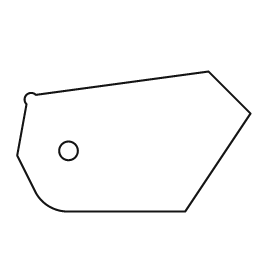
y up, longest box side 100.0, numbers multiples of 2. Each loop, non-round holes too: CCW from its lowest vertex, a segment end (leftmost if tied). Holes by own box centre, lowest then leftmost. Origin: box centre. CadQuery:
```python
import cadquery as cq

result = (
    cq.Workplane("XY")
    .moveTo(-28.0, -30.0)
    .lineTo(22.0, -30.0)
    .lineTo(50.0, 12.0)
    .lineTo(32.0, 30.0)
    .lineTo(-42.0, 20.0)
    .threePointArc((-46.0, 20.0), (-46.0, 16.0))
    .lineTo(-50.0, -6.0)
    .lineTo(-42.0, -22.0)
    .threePointArc((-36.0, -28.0), (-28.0, -30.0))
    .close()
    .moveTo(-28.0, -4.0)
    .circle(4.0)
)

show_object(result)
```